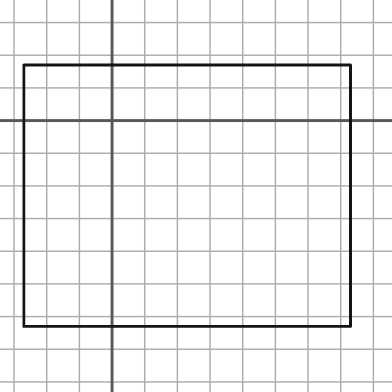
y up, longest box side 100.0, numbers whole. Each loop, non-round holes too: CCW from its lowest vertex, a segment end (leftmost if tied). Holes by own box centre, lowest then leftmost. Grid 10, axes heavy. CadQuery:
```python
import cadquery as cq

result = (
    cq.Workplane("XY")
    .moveTo(-27.0, -63.0)
    .lineTo(73.0, -63.0)
    .lineTo(73.0, 17.0)
    .lineTo(-27.0, 17.0)
    .close()
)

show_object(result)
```